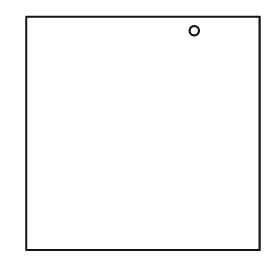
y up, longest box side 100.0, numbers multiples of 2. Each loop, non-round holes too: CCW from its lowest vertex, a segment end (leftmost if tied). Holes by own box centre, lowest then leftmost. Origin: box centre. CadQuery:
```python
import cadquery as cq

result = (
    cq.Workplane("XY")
    .moveTo(-50.0, -50.0)
    .lineTo(50.0, -50.0)
    .lineTo(50.0, 50.0)
    .lineTo(-50.0, 50.0)
    .close()
    .moveTo(22.0, 44.0)
    .circle(2.0)
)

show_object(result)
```